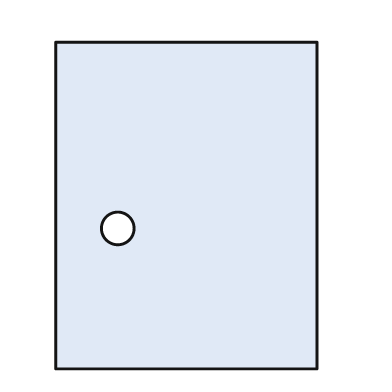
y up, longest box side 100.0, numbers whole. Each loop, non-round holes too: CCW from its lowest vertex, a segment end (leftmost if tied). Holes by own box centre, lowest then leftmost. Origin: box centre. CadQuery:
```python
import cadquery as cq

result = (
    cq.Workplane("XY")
    .moveTo(-40.0, -50.0)
    .lineTo(40.0, -50.0)
    .lineTo(40.0, 50.0)
    .lineTo(-40.0, 50.0)
    .close()
    .moveTo(-21.0, -7.0)
    .circle(5.0)
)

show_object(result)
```